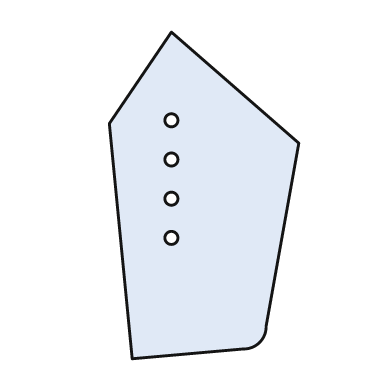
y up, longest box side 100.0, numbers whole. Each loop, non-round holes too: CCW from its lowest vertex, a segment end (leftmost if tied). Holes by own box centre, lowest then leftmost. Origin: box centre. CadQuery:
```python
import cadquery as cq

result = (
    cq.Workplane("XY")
    .moveTo(-22.0, -50.0)
    .lineTo(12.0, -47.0)
    .threePointArc((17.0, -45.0), (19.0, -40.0))
    .lineTo(29.0, 16.0)
    .lineTo(-10.0, 50.0)
    .lineTo(-29.0, 22.0)
    .close()
    .moveTo(-10.0, -13.0)
    .circle(2.0)
    .moveTo(-10.0, -1.0)
    .circle(2.0)
    .moveTo(-10.0, 11.0)
    .circle(2.0)
    .moveTo(-10.0, 23.0)
    .circle(2.0)
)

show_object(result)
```